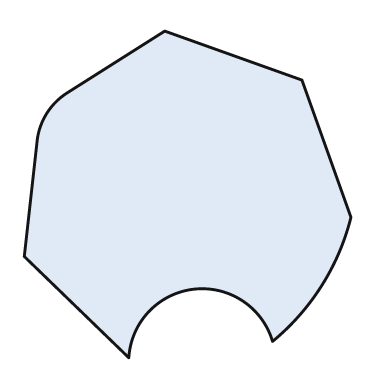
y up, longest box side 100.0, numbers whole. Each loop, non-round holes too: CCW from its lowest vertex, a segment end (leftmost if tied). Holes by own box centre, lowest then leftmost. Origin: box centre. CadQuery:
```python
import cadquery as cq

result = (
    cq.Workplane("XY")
    .moveTo(-18.0, -50.0)
    .threePointArc((2.0, -29.0), (26.0, -45.0))
    .threePointArc((41.0, -28.0), (50.0, -7.0))
    .lineTo(35.0, 35.0)
    .lineTo(-7.0, 50.0)
    .lineTo(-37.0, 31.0)
    .threePointArc((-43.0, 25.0), (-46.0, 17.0))
    .lineTo(-50.0, -19.0)
    .close()
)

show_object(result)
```